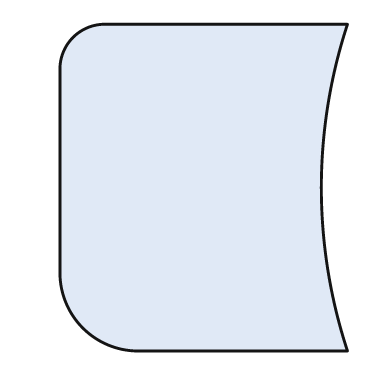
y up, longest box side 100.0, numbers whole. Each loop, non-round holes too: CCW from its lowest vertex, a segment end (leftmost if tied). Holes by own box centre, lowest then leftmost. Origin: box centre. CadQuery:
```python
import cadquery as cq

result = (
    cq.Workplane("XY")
    .moveTo(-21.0, -50.0)
    .lineTo(44.0, -50.0)
    .threePointArc((36.0, 0.0), (44.0, 50.0))
    .lineTo(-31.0, 50.0)
    .threePointArc((-40.0, 46.0), (-44.0, 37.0))
    .lineTo(-44.0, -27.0)
    .threePointArc((-37.0, -43.0), (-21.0, -50.0))
    .close()
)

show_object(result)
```